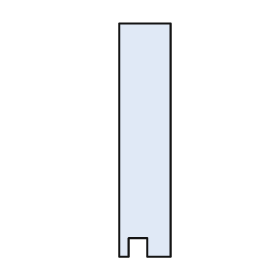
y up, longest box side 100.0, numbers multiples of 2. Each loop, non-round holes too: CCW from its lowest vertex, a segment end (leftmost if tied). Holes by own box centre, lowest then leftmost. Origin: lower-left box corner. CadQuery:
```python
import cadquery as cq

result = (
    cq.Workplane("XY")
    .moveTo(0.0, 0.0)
    .lineTo(4.0, 0.0)
    .lineTo(4.0, 8.0)
    .lineTo(12.0, 8.0)
    .lineTo(12.0, 0.0)
    .lineTo(22.0, 0.0)
    .lineTo(22.0, 100.0)
    .lineTo(0.0, 100.0)
    .close()
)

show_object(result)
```